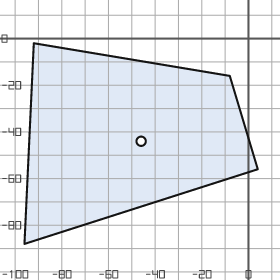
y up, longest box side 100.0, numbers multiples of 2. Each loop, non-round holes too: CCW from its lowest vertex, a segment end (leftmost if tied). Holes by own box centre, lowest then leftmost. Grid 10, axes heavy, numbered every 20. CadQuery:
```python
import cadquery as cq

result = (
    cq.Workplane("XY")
    .moveTo(-96.0, -88.0)
    .lineTo(4.0, -56.0)
    .lineTo(-8.0, -16.0)
    .lineTo(-92.0, -2.0)
    .close()
    .moveTo(-46.0, -44.0)
    .circle(2.0)
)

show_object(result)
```